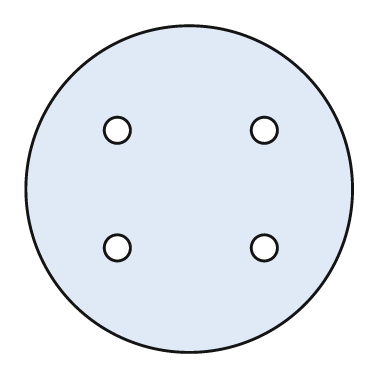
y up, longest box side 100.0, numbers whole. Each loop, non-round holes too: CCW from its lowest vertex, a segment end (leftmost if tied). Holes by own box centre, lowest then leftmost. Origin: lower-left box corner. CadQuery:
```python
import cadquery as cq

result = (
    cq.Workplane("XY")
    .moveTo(50.0, 50.0)
    .circle(50.0)
    .moveTo(28.0, 32.0)
    .circle(4.0)
    .moveTo(73.0, 32.0)
    .circle(4.0)
    .moveTo(28.0, 68.0)
    .circle(4.0)
    .moveTo(73.0, 68.0)
    .circle(4.0)
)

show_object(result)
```